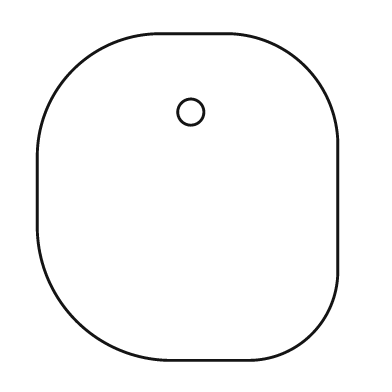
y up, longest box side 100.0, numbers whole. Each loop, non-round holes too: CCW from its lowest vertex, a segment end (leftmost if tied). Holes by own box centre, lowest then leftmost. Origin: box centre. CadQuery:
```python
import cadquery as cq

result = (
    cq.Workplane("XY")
    .moveTo(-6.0, -50.0)
    .lineTo(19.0, -50.0)
    .threePointArc((38.0, -42.0), (46.0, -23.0))
    .lineTo(46.0, 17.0)
    .threePointArc((36.0, 40.0), (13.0, 50.0))
    .lineTo(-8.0, 50.0)
    .threePointArc((-35.0, 39.0), (-46.0, 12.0))
    .lineTo(-46.0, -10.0)
    .threePointArc((-34.0, -38.0), (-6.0, -50.0))
    .close()
    .moveTo(1.0, 26.0)
    .circle(4.0)
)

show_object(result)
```